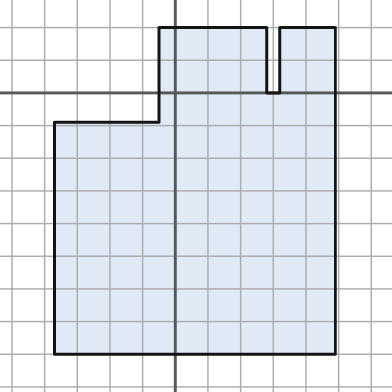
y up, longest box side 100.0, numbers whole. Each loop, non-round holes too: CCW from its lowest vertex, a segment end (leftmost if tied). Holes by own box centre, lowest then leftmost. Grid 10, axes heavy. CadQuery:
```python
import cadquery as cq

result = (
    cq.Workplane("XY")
    .moveTo(-37.0, -80.0)
    .lineTo(49.0, -80.0)
    .lineTo(49.0, 20.0)
    .lineTo(32.0, 20.0)
    .lineTo(32.0, 0.0)
    .lineTo(28.0, 0.0)
    .lineTo(28.0, 20.0)
    .lineTo(-5.0, 20.0)
    .lineTo(-5.0, -9.0)
    .lineTo(-37.0, -9.0)
    .close()
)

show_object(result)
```